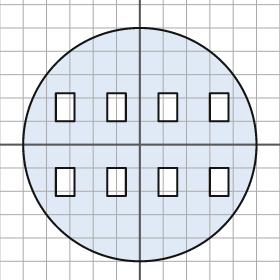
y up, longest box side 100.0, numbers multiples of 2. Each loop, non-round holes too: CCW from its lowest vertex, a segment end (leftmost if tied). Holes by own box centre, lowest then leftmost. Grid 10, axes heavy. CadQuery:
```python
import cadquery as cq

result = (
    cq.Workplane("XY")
    .moveTo(0.0, 0.0)
    .circle(50.0)
    .moveTo(-36.0, -22.0)
    .lineTo(-28.0, -22.0)
    .lineTo(-28.0, -10.0)
    .lineTo(-36.0, -10.0)
    .close()
    .moveTo(-14.0, -22.0)
    .lineTo(-6.0, -22.0)
    .lineTo(-6.0, -10.0)
    .lineTo(-14.0, -10.0)
    .close()
    .moveTo(8.0, -22.0)
    .lineTo(16.0, -22.0)
    .lineTo(16.0, -10.0)
    .lineTo(8.0, -10.0)
    .close()
    .moveTo(30.0, -22.0)
    .lineTo(38.0, -22.0)
    .lineTo(38.0, -10.0)
    .lineTo(30.0, -10.0)
    .close()
    .moveTo(-36.0, 10.0)
    .lineTo(-28.0, 10.0)
    .lineTo(-28.0, 22.0)
    .lineTo(-36.0, 22.0)
    .close()
    .moveTo(-14.0, 10.0)
    .lineTo(-6.0, 10.0)
    .lineTo(-6.0, 22.0)
    .lineTo(-14.0, 22.0)
    .close()
    .moveTo(8.0, 10.0)
    .lineTo(16.0, 10.0)
    .lineTo(16.0, 22.0)
    .lineTo(8.0, 22.0)
    .close()
    .moveTo(30.0, 10.0)
    .lineTo(38.0, 10.0)
    .lineTo(38.0, 22.0)
    .lineTo(30.0, 22.0)
    .close()
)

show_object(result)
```